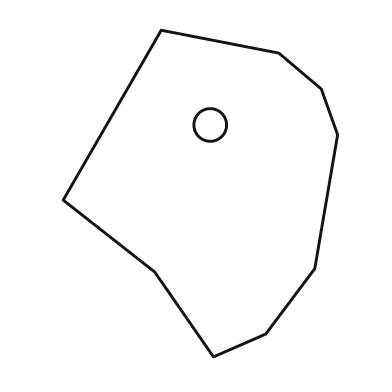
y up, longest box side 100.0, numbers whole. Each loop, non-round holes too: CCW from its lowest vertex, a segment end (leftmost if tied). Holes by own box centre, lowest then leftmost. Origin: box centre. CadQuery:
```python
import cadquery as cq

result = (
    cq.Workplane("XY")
    .moveTo(4.0, -50.0)
    .lineTo(20.0, -43.0)
    .lineTo(35.0, -23.0)
    .lineTo(42.0, 18.0)
    .lineTo(37.0, 32.0)
    .lineTo(24.0, 43.0)
    .lineTo(-12.0, 50.0)
    .lineTo(-42.0, -2.0)
    .lineTo(-14.0, -24.0)
    .close()
    .moveTo(3.0, 21.0)
    .circle(5.0)
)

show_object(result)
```